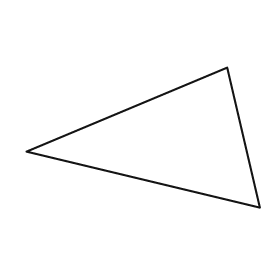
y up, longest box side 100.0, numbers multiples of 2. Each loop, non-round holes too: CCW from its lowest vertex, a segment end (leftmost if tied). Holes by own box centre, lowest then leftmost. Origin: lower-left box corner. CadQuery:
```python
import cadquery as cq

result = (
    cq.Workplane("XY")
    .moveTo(100.0, 0.0)
    .lineTo(86.0, 60.0)
    .lineTo(0.0, 24.0)
    .close()
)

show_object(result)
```